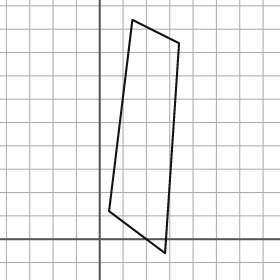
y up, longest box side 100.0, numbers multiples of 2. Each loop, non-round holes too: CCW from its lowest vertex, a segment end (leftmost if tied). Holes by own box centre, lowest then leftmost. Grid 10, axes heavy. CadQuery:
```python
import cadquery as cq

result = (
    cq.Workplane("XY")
    .moveTo(28.0, -6.0)
    .lineTo(34.0, 84.0)
    .lineTo(14.0, 94.0)
    .lineTo(4.0, 12.0)
    .close()
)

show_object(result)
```